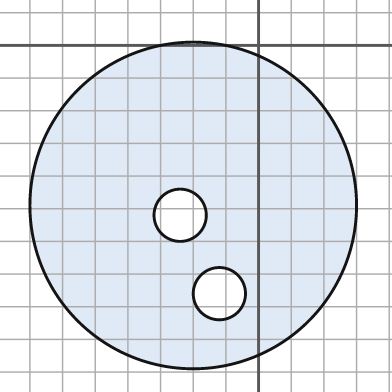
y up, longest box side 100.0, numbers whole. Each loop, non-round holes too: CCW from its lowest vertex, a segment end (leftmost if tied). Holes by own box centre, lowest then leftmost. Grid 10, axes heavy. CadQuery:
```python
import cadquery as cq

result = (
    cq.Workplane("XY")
    .moveTo(-20.0, -49.0)
    .circle(50.0)
    .moveTo(-12.0, -76.0)
    .circle(8.0)
    .moveTo(-24.0, -52.0)
    .circle(8.0)
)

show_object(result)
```